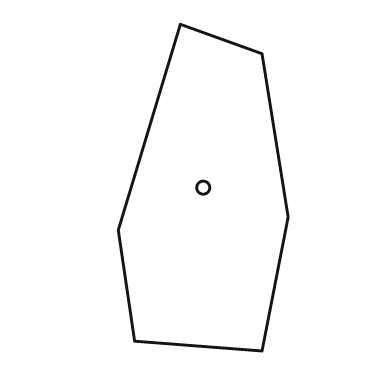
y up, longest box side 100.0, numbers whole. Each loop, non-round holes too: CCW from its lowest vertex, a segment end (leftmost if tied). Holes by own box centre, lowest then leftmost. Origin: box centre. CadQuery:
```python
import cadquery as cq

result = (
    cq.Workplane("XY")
    .moveTo(18.0, -50.0)
    .lineTo(26.0, -9.0)
    .lineTo(18.0, 41.0)
    .lineTo(-7.0, 50.0)
    .lineTo(-26.0, -13.0)
    .lineTo(-21.0, -47.0)
    .close()
    .moveTo(0.0, 0.0)
    .circle(2.0)
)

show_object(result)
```